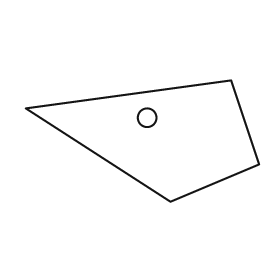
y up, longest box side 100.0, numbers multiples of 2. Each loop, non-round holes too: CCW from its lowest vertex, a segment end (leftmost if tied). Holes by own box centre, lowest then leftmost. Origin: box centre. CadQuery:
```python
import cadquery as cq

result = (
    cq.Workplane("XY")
    .moveTo(12.0, -26.0)
    .lineTo(50.0, -10.0)
    .lineTo(38.0, 26.0)
    .lineTo(-50.0, 14.0)
    .close()
    .moveTo(2.0, 10.0)
    .circle(4.0)
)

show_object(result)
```